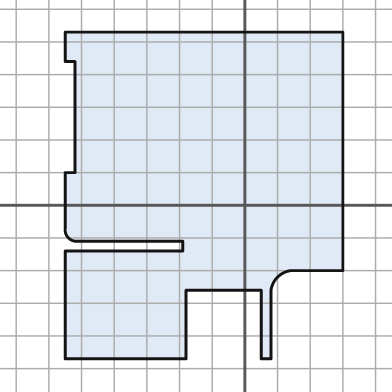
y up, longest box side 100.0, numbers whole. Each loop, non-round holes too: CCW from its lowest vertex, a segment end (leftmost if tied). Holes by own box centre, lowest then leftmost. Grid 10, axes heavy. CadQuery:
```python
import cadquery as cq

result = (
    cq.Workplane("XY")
    .moveTo(-55.0, -47.0)
    .lineTo(-18.0, -47.0)
    .lineTo(-18.0, -26.0)
    .lineTo(5.0, -26.0)
    .lineTo(5.0, -47.0)
    .lineTo(8.0, -47.0)
    .lineTo(8.0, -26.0)
    .threePointArc((10.0, -22.0), (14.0, -20.0))
    .lineTo(30.0, -20.0)
    .lineTo(30.0, 53.0)
    .lineTo(-55.0, 53.0)
    .lineTo(-55.0, 44.0)
    .lineTo(-52.0, 44.0)
    .lineTo(-52.0, 10.0)
    .lineTo(-55.0, 10.0)
    .lineTo(-55.0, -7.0)
    .threePointArc((-54.0, -10.0), (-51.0, -11.0))
    .lineTo(-19.0, -11.0)
    .lineTo(-19.0, -14.0)
    .lineTo(-55.0, -14.0)
    .close()
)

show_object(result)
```